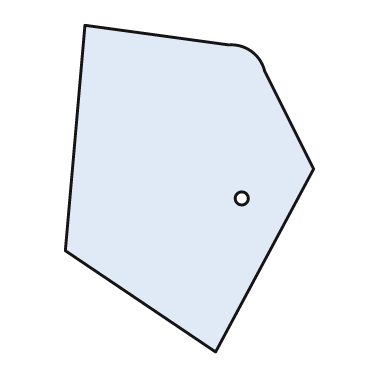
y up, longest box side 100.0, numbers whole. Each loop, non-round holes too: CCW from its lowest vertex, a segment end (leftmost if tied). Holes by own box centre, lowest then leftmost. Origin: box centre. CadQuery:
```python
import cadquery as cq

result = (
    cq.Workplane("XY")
    .moveTo(8.0, -50.0)
    .lineTo(38.0, 6.0)
    .lineTo(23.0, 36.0)
    .threePointArc((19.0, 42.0), (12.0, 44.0))
    .lineTo(-32.0, 50.0)
    .lineTo(-38.0, -19.0)
    .close()
    .moveTo(16.0, -3.0)
    .circle(2.0)
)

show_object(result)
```